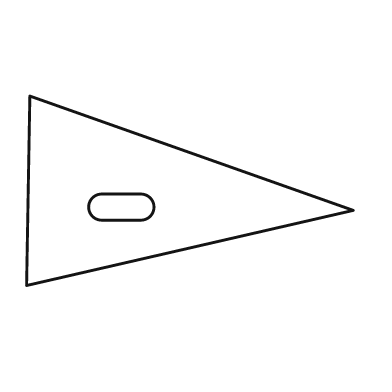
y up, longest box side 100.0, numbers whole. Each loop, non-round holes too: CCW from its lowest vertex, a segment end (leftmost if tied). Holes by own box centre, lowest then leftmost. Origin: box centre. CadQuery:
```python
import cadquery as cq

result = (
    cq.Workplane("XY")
    .moveTo(-50.0, -29.0)
    .lineTo(50.0, -6.0)
    .lineTo(-49.0, 29.0)
    .close()
    .moveTo(-27.0, -9.0)
    .lineTo(-15.0, -9.0)
    .threePointArc((-11.0, -5.0), (-15.0, -1.0))
    .lineTo(-27.0, -1.0)
    .threePointArc((-31.0, -5.0), (-27.0, -9.0))
    .close()
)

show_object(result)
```